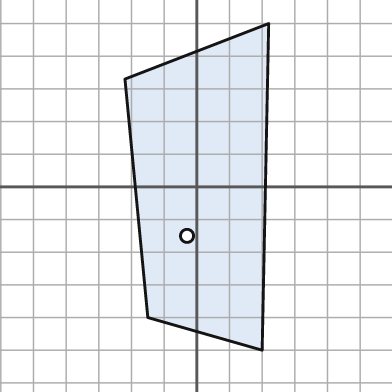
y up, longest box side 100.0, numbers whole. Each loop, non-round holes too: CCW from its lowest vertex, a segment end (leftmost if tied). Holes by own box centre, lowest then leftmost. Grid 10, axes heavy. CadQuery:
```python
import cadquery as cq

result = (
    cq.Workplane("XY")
    .moveTo(20.0, -50.0)
    .lineTo(22.0, 50.0)
    .lineTo(-22.0, 33.0)
    .lineTo(-15.0, -40.0)
    .close()
    .moveTo(-3.0, -15.0)
    .circle(2.0)
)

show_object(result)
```